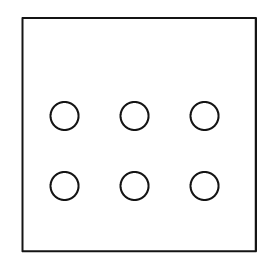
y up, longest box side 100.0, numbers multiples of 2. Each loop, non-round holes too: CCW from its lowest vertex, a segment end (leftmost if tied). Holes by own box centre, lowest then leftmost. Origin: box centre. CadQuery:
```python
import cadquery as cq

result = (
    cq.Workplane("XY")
    .moveTo(-50.0, -50.0)
    .lineTo(50.0, -50.0)
    .lineTo(50.0, 50.0)
    .lineTo(-50.0, 50.0)
    .close()
    .moveTo(-32.0, -22.0)
    .circle(6.0)
    .moveTo(-2.0, -22.0)
    .circle(6.0)
    .moveTo(28.0, -22.0)
    .circle(6.0)
    .moveTo(-32.0, 8.0)
    .circle(6.0)
    .moveTo(-2.0, 8.0)
    .circle(6.0)
    .moveTo(28.0, 8.0)
    .circle(6.0)
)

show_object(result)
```